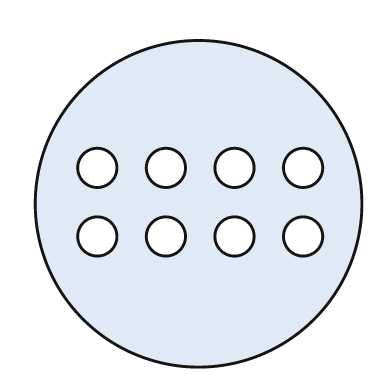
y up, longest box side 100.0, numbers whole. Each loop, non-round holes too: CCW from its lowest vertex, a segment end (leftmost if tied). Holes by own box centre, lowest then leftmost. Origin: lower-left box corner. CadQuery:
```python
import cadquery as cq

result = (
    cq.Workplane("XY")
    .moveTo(50.0, 50.0)
    .circle(50.0)
    .moveTo(19.0, 40.0)
    .circle(6.0)
    .moveTo(40.0, 40.0)
    .circle(6.0)
    .moveTo(61.0, 40.0)
    .circle(6.0)
    .moveTo(82.0, 40.0)
    .circle(6.0)
    .moveTo(19.0, 61.0)
    .circle(6.0)
    .moveTo(40.0, 61.0)
    .circle(6.0)
    .moveTo(61.0, 61.0)
    .circle(6.0)
    .moveTo(82.0, 61.0)
    .circle(6.0)
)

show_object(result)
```